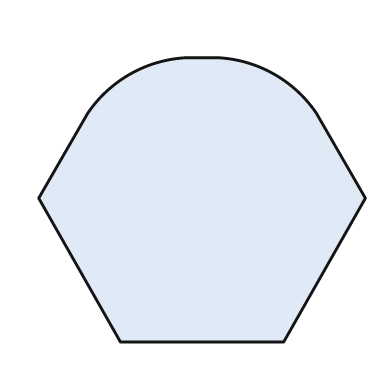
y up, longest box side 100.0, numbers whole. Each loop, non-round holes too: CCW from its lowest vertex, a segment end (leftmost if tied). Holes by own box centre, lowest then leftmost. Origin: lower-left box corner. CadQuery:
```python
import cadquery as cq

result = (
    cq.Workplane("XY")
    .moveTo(25.0, 0.0)
    .lineTo(75.0, 0.0)
    .lineTo(100.0, 44.0)
    .lineTo(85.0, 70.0)
    .threePointArc((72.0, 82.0), (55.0, 87.0))
    .lineTo(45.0, 87.0)
    .threePointArc((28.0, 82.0), (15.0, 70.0))
    .lineTo(0.0, 44.0)
    .close()
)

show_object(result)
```